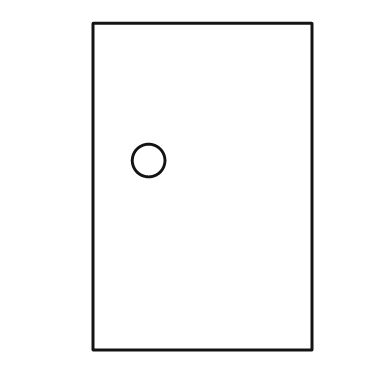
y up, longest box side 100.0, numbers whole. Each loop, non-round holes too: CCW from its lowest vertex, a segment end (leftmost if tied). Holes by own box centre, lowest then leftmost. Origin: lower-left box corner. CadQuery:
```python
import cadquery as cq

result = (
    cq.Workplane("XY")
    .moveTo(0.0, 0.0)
    .lineTo(67.0, 0.0)
    .lineTo(67.0, 100.0)
    .lineTo(0.0, 100.0)
    .close()
    .moveTo(17.0, 58.0)
    .circle(5.0)
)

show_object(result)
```